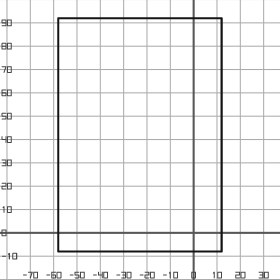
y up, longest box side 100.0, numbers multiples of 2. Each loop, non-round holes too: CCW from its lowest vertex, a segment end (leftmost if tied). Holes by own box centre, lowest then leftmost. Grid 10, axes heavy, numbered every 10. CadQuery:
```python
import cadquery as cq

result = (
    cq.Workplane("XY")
    .moveTo(-58.0, -8.0)
    .lineTo(12.0, -8.0)
    .lineTo(12.0, 92.0)
    .lineTo(-58.0, 92.0)
    .close()
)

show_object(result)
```